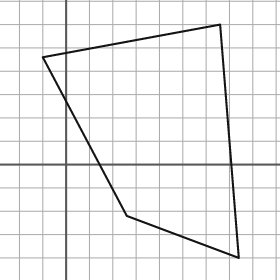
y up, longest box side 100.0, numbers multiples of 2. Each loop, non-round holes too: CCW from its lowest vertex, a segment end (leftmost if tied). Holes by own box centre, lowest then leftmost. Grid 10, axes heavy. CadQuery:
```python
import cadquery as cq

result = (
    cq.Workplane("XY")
    .moveTo(74.0, -40.0)
    .lineTo(66.0, 60.0)
    .lineTo(-10.0, 46.0)
    .lineTo(26.0, -22.0)
    .close()
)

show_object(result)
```